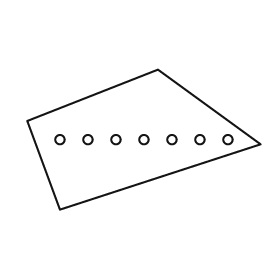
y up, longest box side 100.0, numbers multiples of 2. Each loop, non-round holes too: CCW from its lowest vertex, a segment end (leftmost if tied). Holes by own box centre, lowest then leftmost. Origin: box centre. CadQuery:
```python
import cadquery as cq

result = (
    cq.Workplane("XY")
    .moveTo(-36.0, -30.0)
    .lineTo(50.0, -2.0)
    .lineTo(6.0, 30.0)
    .lineTo(-50.0, 8.0)
    .close()
    .moveTo(-36.0, 0.0)
    .circle(2.0)
    .moveTo(-24.0, 0.0)
    .circle(2.0)
    .moveTo(-12.0, 0.0)
    .circle(2.0)
    .moveTo(0.0, 0.0)
    .circle(2.0)
    .moveTo(12.0, 0.0)
    .circle(2.0)
    .moveTo(24.0, 0.0)
    .circle(2.0)
    .moveTo(36.0, 0.0)
    .circle(2.0)
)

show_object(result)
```